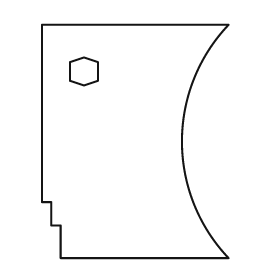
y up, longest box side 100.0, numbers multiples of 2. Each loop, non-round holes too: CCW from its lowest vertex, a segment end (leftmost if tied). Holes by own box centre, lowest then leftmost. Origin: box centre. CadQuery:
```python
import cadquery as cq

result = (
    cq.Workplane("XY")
    .moveTo(-32.0, -50.0)
    .lineTo(40.0, -50.0)
    .threePointArc((20.0, 0.0), (40.0, 50.0))
    .lineTo(-40.0, 50.0)
    .lineTo(-40.0, -26.0)
    .lineTo(-36.0, -26.0)
    .lineTo(-36.0, -36.0)
    .lineTo(-32.0, -36.0)
    .close()
    .moveTo(-22.0, 24.0)
    .lineTo(-16.0, 26.0)
    .lineTo(-16.0, 34.0)
    .lineTo(-22.0, 36.0)
    .lineTo(-28.0, 34.0)
    .lineTo(-28.0, 26.0)
    .close()
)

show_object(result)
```